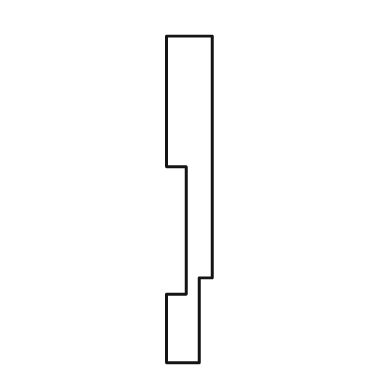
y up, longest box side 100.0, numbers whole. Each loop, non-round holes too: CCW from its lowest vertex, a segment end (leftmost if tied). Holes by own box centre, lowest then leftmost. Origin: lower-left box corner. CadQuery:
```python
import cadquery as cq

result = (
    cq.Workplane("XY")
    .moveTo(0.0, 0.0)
    .lineTo(10.0, 0.0)
    .lineTo(10.0, 26.0)
    .lineTo(14.0, 26.0)
    .lineTo(14.0, 100.0)
    .lineTo(0.0, 100.0)
    .lineTo(0.0, 60.0)
    .lineTo(6.0, 60.0)
    .lineTo(6.0, 21.0)
    .lineTo(0.0, 21.0)
    .close()
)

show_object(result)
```